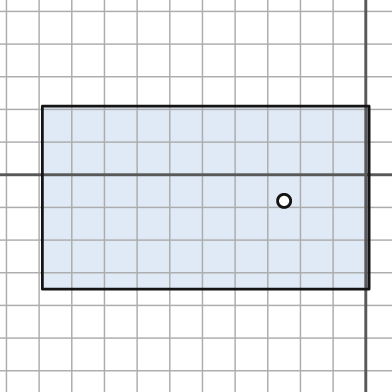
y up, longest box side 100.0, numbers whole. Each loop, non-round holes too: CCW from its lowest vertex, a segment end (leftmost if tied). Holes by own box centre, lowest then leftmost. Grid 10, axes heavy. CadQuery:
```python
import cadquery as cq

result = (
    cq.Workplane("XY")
    .moveTo(-99.0, -35.0)
    .lineTo(1.0, -35.0)
    .lineTo(1.0, 21.0)
    .lineTo(-99.0, 21.0)
    .close()
    .moveTo(-25.0, -8.0)
    .circle(2.0)
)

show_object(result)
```